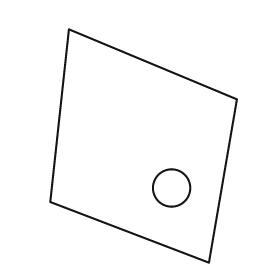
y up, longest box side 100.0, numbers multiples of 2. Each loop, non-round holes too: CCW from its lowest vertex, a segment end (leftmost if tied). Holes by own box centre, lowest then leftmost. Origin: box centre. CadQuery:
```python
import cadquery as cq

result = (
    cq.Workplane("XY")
    .moveTo(28.0, -50.0)
    .lineTo(40.0, 20.0)
    .lineTo(-32.0, 50.0)
    .lineTo(-40.0, -24.0)
    .close()
    .moveTo(12.0, -18.0)
    .circle(8.0)
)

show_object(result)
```